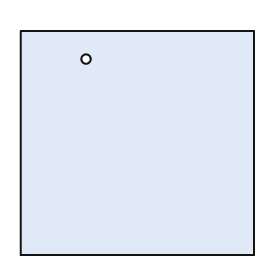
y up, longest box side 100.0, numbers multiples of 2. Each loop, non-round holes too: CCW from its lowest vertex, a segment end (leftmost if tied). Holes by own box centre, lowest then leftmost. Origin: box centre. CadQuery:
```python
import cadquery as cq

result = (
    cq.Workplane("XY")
    .moveTo(-50.0, -48.0)
    .lineTo(50.0, -48.0)
    .lineTo(50.0, 48.0)
    .lineTo(-50.0, 48.0)
    .close()
    .moveTo(-22.0, 36.0)
    .circle(2.0)
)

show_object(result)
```